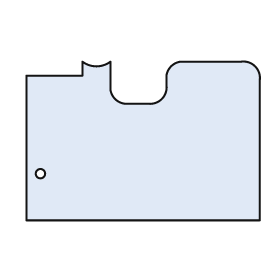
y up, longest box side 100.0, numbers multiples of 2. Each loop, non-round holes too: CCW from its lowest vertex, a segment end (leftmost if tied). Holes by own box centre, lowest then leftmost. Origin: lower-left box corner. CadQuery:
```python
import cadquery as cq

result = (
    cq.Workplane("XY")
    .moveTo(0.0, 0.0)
    .lineTo(100.0, 0.0)
    .lineTo(100.0, 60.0)
    .threePointArc((98.0, 66.0), (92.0, 68.0))
    .lineTo(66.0, 68.0)
    .threePointArc((62.0, 66.0), (60.0, 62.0))
    .lineTo(60.0, 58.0)
    .threePointArc((58.0, 52.0), (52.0, 50.0))
    .lineTo(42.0, 50.0)
    .threePointArc((38.0, 52.0), (36.0, 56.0))
    .lineTo(36.0, 68.0)
    .threePointArc((30.0, 66.0), (24.0, 68.0))
    .lineTo(24.0, 62.0)
    .lineTo(0.0, 62.0)
    .close()
    .moveTo(6.0, 20.0)
    .circle(2.0)
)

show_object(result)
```